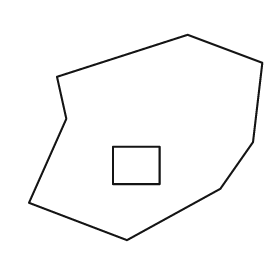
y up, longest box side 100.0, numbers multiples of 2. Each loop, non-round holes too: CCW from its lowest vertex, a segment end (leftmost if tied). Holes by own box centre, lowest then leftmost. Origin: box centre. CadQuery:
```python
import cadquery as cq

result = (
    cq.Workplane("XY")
    .moveTo(-8.0, -44.0)
    .lineTo(32.0, -22.0)
    .lineTo(46.0, -2.0)
    .lineTo(50.0, 32.0)
    .lineTo(18.0, 44.0)
    .lineTo(-38.0, 26.0)
    .lineTo(-34.0, 8.0)
    .lineTo(-50.0, -28.0)
    .close()
    .moveTo(-14.0, -20.0)
    .lineTo(6.0, -20.0)
    .lineTo(6.0, -4.0)
    .lineTo(-14.0, -4.0)
    .close()
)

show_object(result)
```